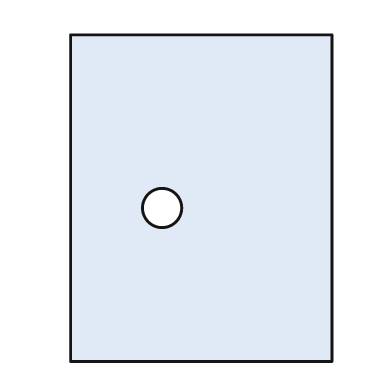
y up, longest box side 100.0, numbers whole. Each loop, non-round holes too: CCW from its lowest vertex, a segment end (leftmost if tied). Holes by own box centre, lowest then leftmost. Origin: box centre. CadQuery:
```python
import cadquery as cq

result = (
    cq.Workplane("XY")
    .moveTo(-40.0, -50.0)
    .lineTo(40.0, -50.0)
    .lineTo(40.0, 50.0)
    .lineTo(-40.0, 50.0)
    .close()
    .moveTo(-12.0, -3.0)
    .circle(6.0)
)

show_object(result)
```